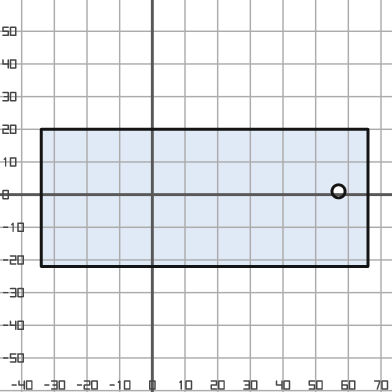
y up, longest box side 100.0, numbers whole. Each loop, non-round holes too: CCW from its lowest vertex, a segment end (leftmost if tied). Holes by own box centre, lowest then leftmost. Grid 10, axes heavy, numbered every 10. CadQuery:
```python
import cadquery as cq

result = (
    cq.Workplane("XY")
    .moveTo(-34.0, -22.0)
    .lineTo(66.0, -22.0)
    .lineTo(66.0, 20.0)
    .lineTo(-34.0, 20.0)
    .close()
    .moveTo(57.0, 1.0)
    .circle(2.0)
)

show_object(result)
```